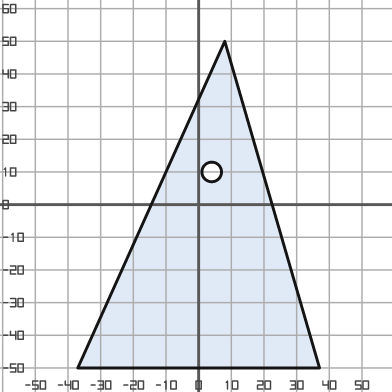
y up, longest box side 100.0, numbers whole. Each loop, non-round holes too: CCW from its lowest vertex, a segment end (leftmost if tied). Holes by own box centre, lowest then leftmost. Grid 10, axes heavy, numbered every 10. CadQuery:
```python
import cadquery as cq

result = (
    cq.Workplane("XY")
    .moveTo(-37.0, -50.0)
    .lineTo(37.0, -50.0)
    .lineTo(8.0, 50.0)
    .close()
    .moveTo(4.0, 10.0)
    .circle(3.0)
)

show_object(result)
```